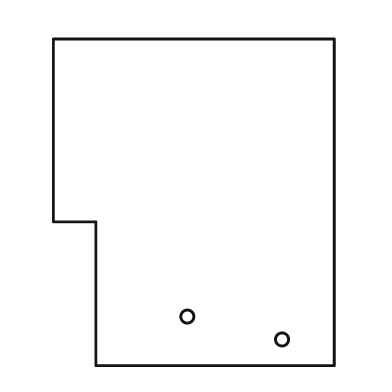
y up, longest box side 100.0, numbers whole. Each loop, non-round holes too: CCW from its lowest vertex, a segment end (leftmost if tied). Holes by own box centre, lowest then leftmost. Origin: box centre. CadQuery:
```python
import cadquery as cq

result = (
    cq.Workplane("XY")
    .moveTo(-30.0, -50.0)
    .lineTo(43.0, -50.0)
    .lineTo(43.0, 50.0)
    .lineTo(-43.0, 50.0)
    .lineTo(-43.0, -6.0)
    .lineTo(-30.0, -6.0)
    .close()
    .moveTo(27.0, -42.0)
    .circle(2.0)
    .moveTo(-2.0, -35.0)
    .circle(2.0)
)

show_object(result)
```